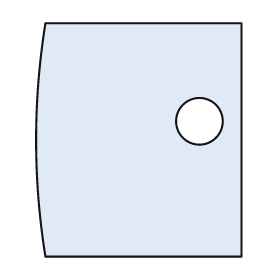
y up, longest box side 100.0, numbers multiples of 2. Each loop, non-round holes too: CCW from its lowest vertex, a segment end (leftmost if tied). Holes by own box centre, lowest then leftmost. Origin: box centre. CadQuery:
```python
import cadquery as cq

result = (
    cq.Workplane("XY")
    .moveTo(-40.0, -50.0)
    .lineTo(44.0, -50.0)
    .lineTo(44.0, 50.0)
    .lineTo(-40.0, 50.0)
    .threePointArc((-44.0, 0.0), (-40.0, -50.0))
    .close()
    .moveTo(26.0, 8.0)
    .circle(10.0)
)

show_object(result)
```